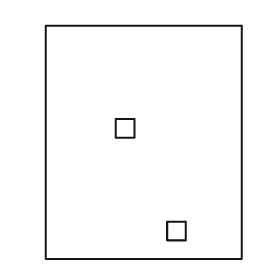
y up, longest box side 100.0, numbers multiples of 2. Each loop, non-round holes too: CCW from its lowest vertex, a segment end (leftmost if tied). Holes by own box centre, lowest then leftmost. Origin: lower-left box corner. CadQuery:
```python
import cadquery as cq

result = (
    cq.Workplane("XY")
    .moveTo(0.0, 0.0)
    .lineTo(84.0, 0.0)
    .lineTo(84.0, 100.0)
    .lineTo(0.0, 100.0)
    .close()
    .moveTo(52.0, 8.0)
    .lineTo(60.0, 8.0)
    .lineTo(60.0, 16.0)
    .lineTo(52.0, 16.0)
    .close()
    .moveTo(30.0, 52.0)
    .lineTo(38.0, 52.0)
    .lineTo(38.0, 60.0)
    .lineTo(30.0, 60.0)
    .close()
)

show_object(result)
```